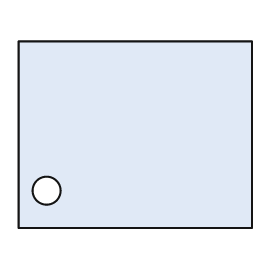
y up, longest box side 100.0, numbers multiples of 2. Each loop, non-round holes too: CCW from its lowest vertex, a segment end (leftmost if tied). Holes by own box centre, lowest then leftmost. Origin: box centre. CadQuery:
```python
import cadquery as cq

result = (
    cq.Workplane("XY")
    .moveTo(-50.0, -40.0)
    .lineTo(50.0, -40.0)
    .lineTo(50.0, 40.0)
    .lineTo(-50.0, 40.0)
    .close()
    .moveTo(-38.0, -24.0)
    .circle(6.0)
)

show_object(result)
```